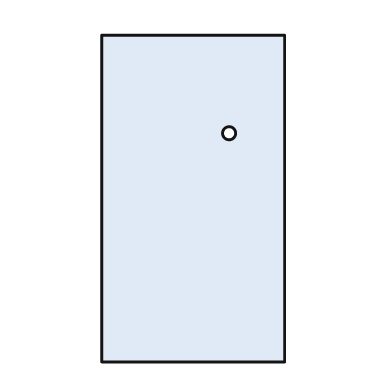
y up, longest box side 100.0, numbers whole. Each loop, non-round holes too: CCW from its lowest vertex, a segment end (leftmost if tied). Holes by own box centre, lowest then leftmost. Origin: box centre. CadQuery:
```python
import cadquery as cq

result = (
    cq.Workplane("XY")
    .moveTo(-28.0, -50.0)
    .lineTo(28.0, -50.0)
    .lineTo(28.0, 50.0)
    .lineTo(-28.0, 50.0)
    .close()
    .moveTo(11.0, 20.0)
    .circle(2.0)
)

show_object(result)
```